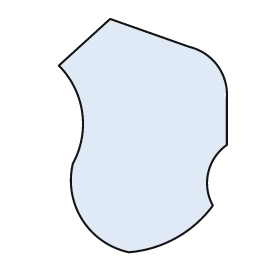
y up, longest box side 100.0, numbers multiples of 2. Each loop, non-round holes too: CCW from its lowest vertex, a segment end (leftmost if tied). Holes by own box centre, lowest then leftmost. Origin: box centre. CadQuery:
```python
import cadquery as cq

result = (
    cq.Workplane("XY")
    .moveTo(-6.0, -50.0)
    .threePointArc((14.0, -44.0), (30.0, -30.0))
    .threePointArc((28.0, -16.0), (36.0, -4.0))
    .lineTo(36.0, 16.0)
    .threePointArc((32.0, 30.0), (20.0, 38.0))
    .lineTo(-14.0, 50.0)
    .lineTo(-36.0, 30.0)
    .threePointArc((-26.0, 10.0), (-30.0, -12.0))
    .threePointArc((-26.0, -36.0), (-6.0, -50.0))
    .close()
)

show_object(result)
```